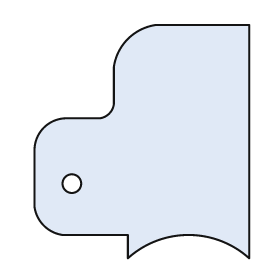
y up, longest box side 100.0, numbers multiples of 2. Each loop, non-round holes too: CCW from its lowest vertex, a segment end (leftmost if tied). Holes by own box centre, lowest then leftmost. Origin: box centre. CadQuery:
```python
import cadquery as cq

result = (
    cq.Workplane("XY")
    .moveTo(-6.0, -50.0)
    .threePointArc((20.0, -40.0), (46.0, -50.0))
    .lineTo(46.0, 50.0)
    .lineTo(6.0, 50.0)
    .threePointArc((-6.0, 44.0), (-12.0, 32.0))
    .lineTo(-12.0, 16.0)
    .threePointArc((-14.0, 12.0), (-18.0, 10.0))
    .lineTo(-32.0, 10.0)
    .threePointArc((-42.0, 6.0), (-46.0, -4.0))
    .lineTo(-46.0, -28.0)
    .threePointArc((-42.0, -36.0), (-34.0, -40.0))
    .lineTo(-6.0, -40.0)
    .close()
    .moveTo(-30.0, -18.0)
    .circle(4.0)
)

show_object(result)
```